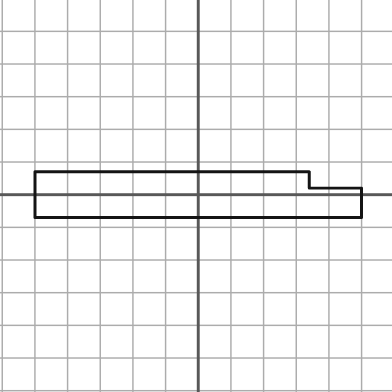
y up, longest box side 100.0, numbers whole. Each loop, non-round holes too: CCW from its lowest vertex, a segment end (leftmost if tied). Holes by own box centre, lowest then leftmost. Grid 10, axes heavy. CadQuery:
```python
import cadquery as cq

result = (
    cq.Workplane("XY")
    .moveTo(-50.0, -7.0)
    .lineTo(50.0, -7.0)
    .lineTo(50.0, 2.0)
    .lineTo(34.0, 2.0)
    .lineTo(34.0, 7.0)
    .lineTo(-50.0, 7.0)
    .close()
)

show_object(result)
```